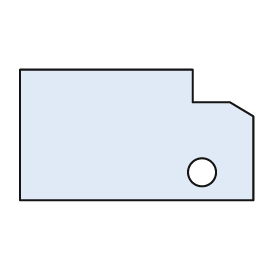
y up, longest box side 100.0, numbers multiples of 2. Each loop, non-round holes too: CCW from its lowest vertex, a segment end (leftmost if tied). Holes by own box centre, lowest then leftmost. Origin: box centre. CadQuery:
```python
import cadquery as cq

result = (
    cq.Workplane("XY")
    .moveTo(-50.0, -28.0)
    .lineTo(50.0, -28.0)
    .lineTo(50.0, 8.0)
    .lineTo(40.0, 14.0)
    .lineTo(24.0, 14.0)
    .lineTo(24.0, 28.0)
    .lineTo(-50.0, 28.0)
    .close()
    .moveTo(28.0, -16.0)
    .circle(6.0)
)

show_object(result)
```